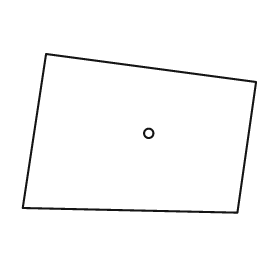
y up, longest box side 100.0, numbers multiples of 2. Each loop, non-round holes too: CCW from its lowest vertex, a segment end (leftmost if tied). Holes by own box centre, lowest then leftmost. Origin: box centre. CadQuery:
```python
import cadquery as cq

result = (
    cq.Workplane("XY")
    .moveTo(42.0, -34.0)
    .lineTo(50.0, 22.0)
    .lineTo(-40.0, 34.0)
    .lineTo(-50.0, -32.0)
    .close()
    .moveTo(4.0, 0.0)
    .circle(2.0)
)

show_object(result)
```